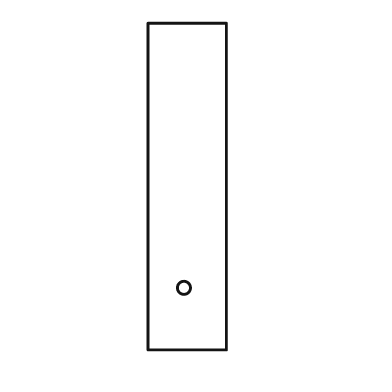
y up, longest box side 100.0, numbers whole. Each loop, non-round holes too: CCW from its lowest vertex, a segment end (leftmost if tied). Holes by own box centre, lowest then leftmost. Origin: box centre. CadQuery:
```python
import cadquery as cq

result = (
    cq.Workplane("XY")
    .moveTo(-12.0, -50.0)
    .lineTo(12.0, -50.0)
    .lineTo(12.0, 50.0)
    .lineTo(-12.0, 50.0)
    .close()
    .moveTo(-1.0, -31.0)
    .circle(2.0)
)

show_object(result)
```